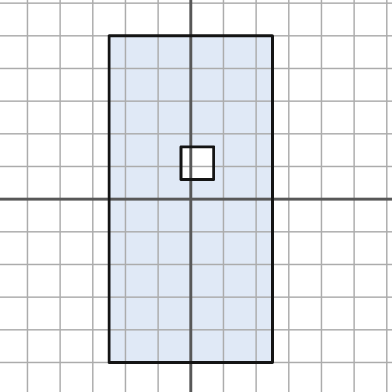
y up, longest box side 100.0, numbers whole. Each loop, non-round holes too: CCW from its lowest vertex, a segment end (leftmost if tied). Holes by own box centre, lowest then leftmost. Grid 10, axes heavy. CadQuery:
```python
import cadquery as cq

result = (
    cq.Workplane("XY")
    .moveTo(-25.0, -50.0)
    .lineTo(25.0, -50.0)
    .lineTo(25.0, 50.0)
    .lineTo(-25.0, 50.0)
    .close()
    .moveTo(-3.0, 6.0)
    .lineTo(7.0, 6.0)
    .lineTo(7.0, 16.0)
    .lineTo(-3.0, 16.0)
    .close()
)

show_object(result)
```